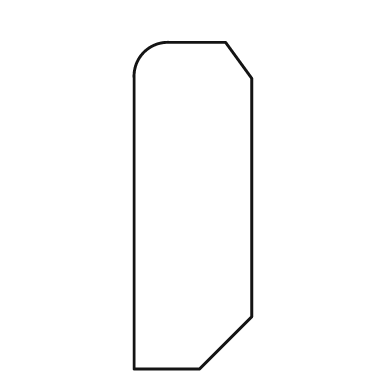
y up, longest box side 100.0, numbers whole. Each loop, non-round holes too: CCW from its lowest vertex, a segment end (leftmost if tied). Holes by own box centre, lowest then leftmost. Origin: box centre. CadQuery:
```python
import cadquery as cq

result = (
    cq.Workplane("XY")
    .moveTo(-18.0, -50.0)
    .lineTo(2.0, -50.0)
    .lineTo(18.0, -34.0)
    .lineTo(18.0, 39.0)
    .lineTo(10.0, 50.0)
    .lineTo(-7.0, 50.0)
    .threePointArc((-15.0, 47.0), (-18.0, 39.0))
    .close()
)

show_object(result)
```